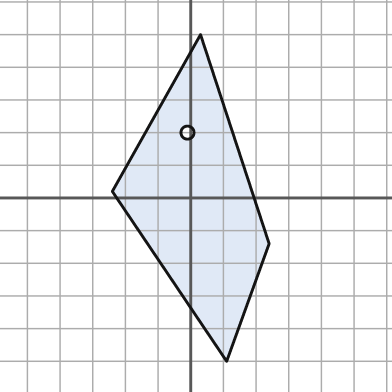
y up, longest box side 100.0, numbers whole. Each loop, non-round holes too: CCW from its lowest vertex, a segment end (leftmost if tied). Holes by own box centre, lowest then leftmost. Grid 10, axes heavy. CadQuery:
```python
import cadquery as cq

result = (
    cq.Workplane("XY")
    .moveTo(11.0, -50.0)
    .lineTo(24.0, -14.0)
    .lineTo(3.0, 50.0)
    .lineTo(-24.0, 2.0)
    .close()
    .moveTo(-1.0, 20.0)
    .circle(2.0)
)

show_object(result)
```